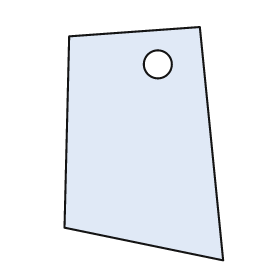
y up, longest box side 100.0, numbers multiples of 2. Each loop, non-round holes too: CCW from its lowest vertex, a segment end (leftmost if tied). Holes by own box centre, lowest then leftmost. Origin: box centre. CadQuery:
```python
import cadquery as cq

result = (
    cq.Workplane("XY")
    .moveTo(34.0, -50.0)
    .lineTo(24.0, 50.0)
    .lineTo(-32.0, 46.0)
    .lineTo(-34.0, -36.0)
    .close()
    .moveTo(6.0, 34.0)
    .circle(6.0)
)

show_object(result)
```